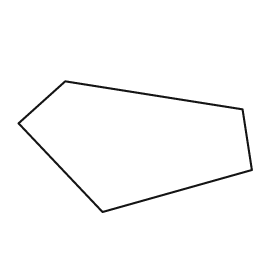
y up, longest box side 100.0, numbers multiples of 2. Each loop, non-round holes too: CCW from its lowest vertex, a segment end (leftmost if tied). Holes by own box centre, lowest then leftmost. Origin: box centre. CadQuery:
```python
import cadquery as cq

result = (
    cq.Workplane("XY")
    .moveTo(-14.0, -28.0)
    .lineTo(50.0, -10.0)
    .lineTo(46.0, 16.0)
    .lineTo(-30.0, 28.0)
    .lineTo(-50.0, 10.0)
    .close()
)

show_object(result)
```